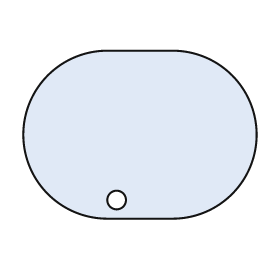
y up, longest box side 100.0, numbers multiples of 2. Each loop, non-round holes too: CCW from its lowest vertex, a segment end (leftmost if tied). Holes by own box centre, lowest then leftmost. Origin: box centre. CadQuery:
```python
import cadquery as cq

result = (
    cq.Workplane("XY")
    .moveTo(-14.0, -36.0)
    .lineTo(14.0, -36.0)
    .threePointArc((50.0, 0.0), (14.0, 36.0))
    .lineTo(-14.0, 36.0)
    .threePointArc((-50.0, 0.0), (-14.0, -36.0))
    .close()
    .moveTo(-10.0, -28.0)
    .circle(4.0)
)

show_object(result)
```